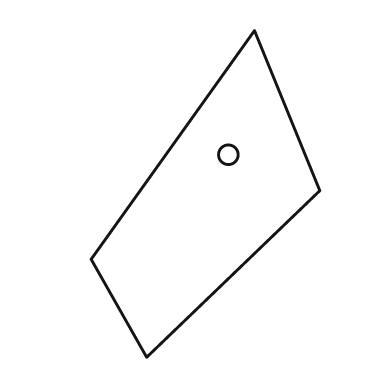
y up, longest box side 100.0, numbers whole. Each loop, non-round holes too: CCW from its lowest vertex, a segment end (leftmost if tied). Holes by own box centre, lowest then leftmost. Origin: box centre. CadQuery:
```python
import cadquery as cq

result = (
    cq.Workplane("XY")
    .moveTo(-18.0, -50.0)
    .lineTo(35.0, 1.0)
    .lineTo(15.0, 50.0)
    .lineTo(-35.0, -20.0)
    .close()
    .moveTo(7.0, 12.0)
    .circle(3.0)
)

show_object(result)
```